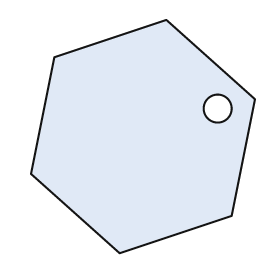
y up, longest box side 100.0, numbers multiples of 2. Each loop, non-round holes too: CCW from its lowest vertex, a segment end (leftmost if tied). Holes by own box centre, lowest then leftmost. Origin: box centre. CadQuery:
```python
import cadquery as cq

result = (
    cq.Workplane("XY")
    .moveTo(-10.0, -50.0)
    .lineTo(38.0, -34.0)
    .lineTo(48.0, 16.0)
    .lineTo(10.0, 50.0)
    .lineTo(-38.0, 34.0)
    .lineTo(-48.0, -16.0)
    .close()
    .moveTo(32.0, 12.0)
    .circle(6.0)
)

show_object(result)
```